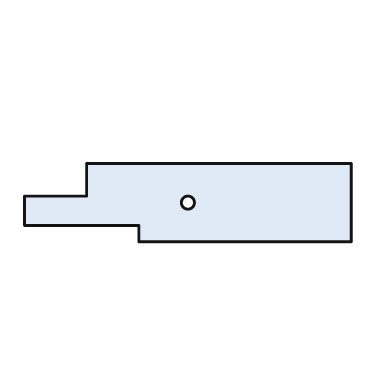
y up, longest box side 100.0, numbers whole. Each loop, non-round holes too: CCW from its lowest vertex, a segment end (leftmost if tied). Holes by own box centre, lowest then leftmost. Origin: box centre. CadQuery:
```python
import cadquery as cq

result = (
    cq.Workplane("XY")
    .moveTo(-15.0, -12.0)
    .lineTo(50.0, -12.0)
    .lineTo(50.0, 12.0)
    .lineTo(-31.0, 12.0)
    .lineTo(-31.0, 2.0)
    .lineTo(-50.0, 2.0)
    .lineTo(-50.0, -7.0)
    .lineTo(-15.0, -7.0)
    .close()
    .moveTo(0.0, 0.0)
    .circle(2.0)
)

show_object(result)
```